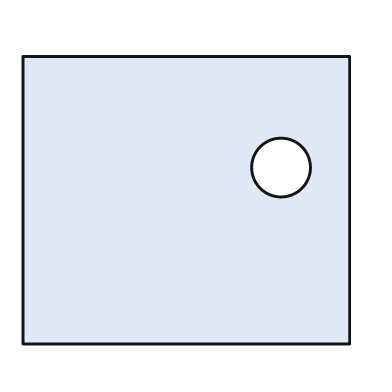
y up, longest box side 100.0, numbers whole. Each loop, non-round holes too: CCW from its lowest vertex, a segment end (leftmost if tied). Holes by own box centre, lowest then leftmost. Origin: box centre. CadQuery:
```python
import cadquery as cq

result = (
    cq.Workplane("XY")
    .moveTo(-50.0, -44.0)
    .lineTo(50.0, -44.0)
    .lineTo(50.0, 44.0)
    .lineTo(-50.0, 44.0)
    .close()
    .moveTo(29.0, 10.0)
    .circle(9.0)
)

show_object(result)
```